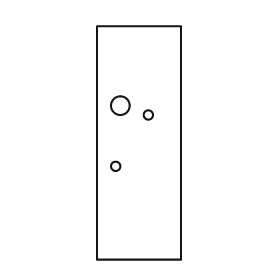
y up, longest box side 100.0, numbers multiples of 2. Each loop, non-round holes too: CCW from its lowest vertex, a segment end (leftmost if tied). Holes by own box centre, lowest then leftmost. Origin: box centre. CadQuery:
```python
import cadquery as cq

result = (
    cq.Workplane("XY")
    .moveTo(-18.0, -50.0)
    .lineTo(18.0, -50.0)
    .lineTo(18.0, 50.0)
    .lineTo(-18.0, 50.0)
    .close()
    .moveTo(-10.0, -10.0)
    .circle(2.0)
    .moveTo(4.0, 12.0)
    .circle(2.0)
    .moveTo(-8.0, 16.0)
    .circle(4.0)
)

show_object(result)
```